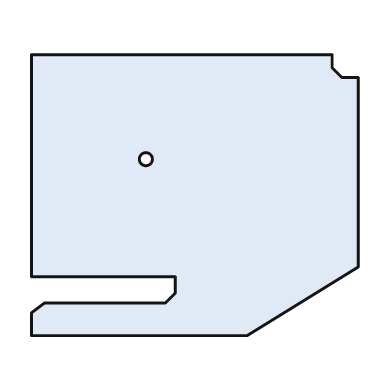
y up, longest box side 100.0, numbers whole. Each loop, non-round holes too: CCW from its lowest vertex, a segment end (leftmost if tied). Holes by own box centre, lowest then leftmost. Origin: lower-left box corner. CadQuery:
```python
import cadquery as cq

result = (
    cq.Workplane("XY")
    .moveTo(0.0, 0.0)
    .lineTo(66.0, 0.0)
    .lineTo(100.0, 21.0)
    .lineTo(100.0, 79.0)
    .lineTo(95.0, 79.0)
    .lineTo(92.0, 82.0)
    .lineTo(92.0, 86.0)
    .lineTo(0.0, 86.0)
    .lineTo(0.0, 18.0)
    .lineTo(44.0, 18.0)
    .lineTo(44.0, 13.0)
    .lineTo(41.0, 10.0)
    .lineTo(4.0, 10.0)
    .lineTo(0.0, 7.0)
    .close()
    .moveTo(35.0, 54.0)
    .circle(2.0)
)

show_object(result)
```